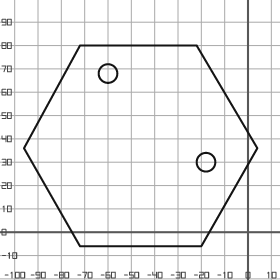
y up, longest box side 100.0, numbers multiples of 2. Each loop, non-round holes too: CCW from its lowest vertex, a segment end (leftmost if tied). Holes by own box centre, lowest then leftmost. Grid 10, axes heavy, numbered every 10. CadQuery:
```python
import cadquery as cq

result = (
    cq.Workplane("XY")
    .moveTo(-72.0, -6.0)
    .lineTo(-20.0, -6.0)
    .lineTo(4.0, 36.0)
    .lineTo(-22.0, 80.0)
    .lineTo(-72.0, 80.0)
    .lineTo(-96.0, 36.0)
    .close()
    .moveTo(-18.0, 30.0)
    .circle(4.0)
    .moveTo(-60.0, 68.0)
    .circle(4.0)
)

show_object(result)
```